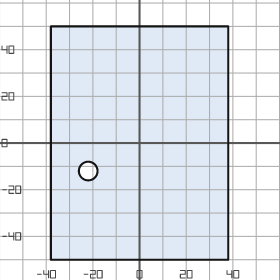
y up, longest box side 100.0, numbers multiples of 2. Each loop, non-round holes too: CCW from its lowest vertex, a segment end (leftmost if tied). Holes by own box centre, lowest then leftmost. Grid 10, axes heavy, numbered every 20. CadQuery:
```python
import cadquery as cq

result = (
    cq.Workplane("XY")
    .moveTo(-38.0, -50.0)
    .lineTo(38.0, -50.0)
    .lineTo(38.0, 50.0)
    .lineTo(-38.0, 50.0)
    .close()
    .moveTo(-22.0, -12.0)
    .circle(4.0)
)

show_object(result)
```